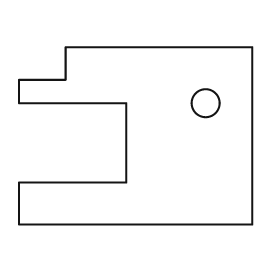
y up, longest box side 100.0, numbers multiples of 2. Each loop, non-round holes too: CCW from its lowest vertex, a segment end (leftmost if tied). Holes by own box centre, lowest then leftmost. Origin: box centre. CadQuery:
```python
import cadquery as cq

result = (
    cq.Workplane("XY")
    .moveTo(-50.0, -38.0)
    .lineTo(50.0, -38.0)
    .lineTo(50.0, 38.0)
    .lineTo(-30.0, 38.0)
    .lineTo(-30.0, 24.0)
    .lineTo(-50.0, 24.0)
    .lineTo(-50.0, 14.0)
    .lineTo(-4.0, 14.0)
    .lineTo(-4.0, -20.0)
    .lineTo(-50.0, -20.0)
    .close()
    .moveTo(30.0, 14.0)
    .circle(6.0)
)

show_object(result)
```